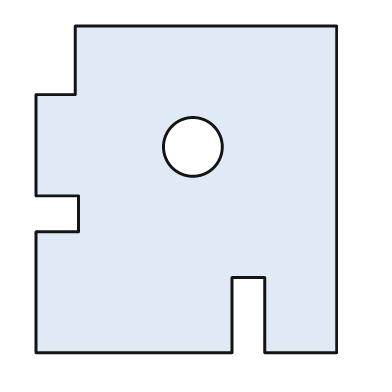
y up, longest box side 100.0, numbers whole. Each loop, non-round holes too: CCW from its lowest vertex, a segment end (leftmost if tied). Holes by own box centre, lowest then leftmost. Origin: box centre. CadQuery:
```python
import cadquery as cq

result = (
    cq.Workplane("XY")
    .moveTo(-46.0, -50.0)
    .lineTo(14.0, -50.0)
    .lineTo(14.0, -27.0)
    .lineTo(24.0, -27.0)
    .lineTo(24.0, -50.0)
    .lineTo(46.0, -50.0)
    .lineTo(46.0, 50.0)
    .lineTo(-34.0, 50.0)
    .lineTo(-34.0, 29.0)
    .lineTo(-46.0, 29.0)
    .lineTo(-46.0, -2.0)
    .lineTo(-33.0, -2.0)
    .lineTo(-33.0, -13.0)
    .lineTo(-46.0, -13.0)
    .close()
    .moveTo(2.0, 13.0)
    .circle(9.0)
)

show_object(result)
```